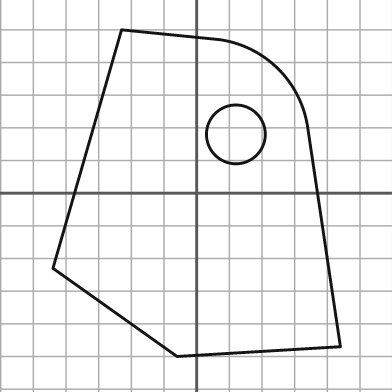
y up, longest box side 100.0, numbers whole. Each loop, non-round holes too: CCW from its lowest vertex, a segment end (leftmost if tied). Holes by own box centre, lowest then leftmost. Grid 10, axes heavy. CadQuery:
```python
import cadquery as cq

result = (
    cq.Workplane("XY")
    .moveTo(-6.0, -50.0)
    .lineTo(44.0, -47.0)
    .lineTo(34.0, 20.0)
    .threePointArc((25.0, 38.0), (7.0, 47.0))
    .lineTo(-23.0, 50.0)
    .lineTo(-44.0, -23.0)
    .close()
    .moveTo(12.0, 18.0)
    .circle(9.0)
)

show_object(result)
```